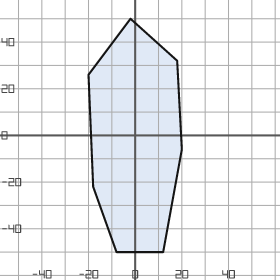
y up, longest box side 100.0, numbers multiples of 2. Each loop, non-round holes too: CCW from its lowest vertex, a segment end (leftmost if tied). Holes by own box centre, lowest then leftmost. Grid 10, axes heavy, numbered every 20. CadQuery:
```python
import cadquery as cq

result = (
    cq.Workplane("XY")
    .moveTo(-8.0, -50.0)
    .lineTo(12.0, -50.0)
    .lineTo(20.0, -6.0)
    .lineTo(18.0, 32.0)
    .lineTo(-2.0, 50.0)
    .lineTo(-20.0, 26.0)
    .lineTo(-18.0, -22.0)
    .close()
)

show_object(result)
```